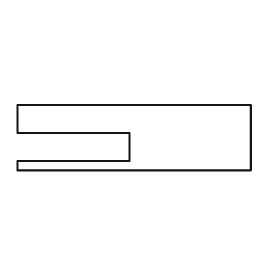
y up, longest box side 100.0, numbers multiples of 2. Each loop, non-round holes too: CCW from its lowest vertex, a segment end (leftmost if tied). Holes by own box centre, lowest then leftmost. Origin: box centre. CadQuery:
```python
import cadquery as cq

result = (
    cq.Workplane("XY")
    .moveTo(-50.0, -14.0)
    .lineTo(50.0, -14.0)
    .lineTo(50.0, 14.0)
    .lineTo(-50.0, 14.0)
    .lineTo(-50.0, 2.0)
    .lineTo(-2.0, 2.0)
    .lineTo(-2.0, -10.0)
    .lineTo(-50.0, -10.0)
    .close()
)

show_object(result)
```